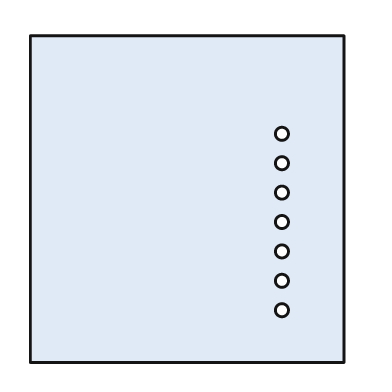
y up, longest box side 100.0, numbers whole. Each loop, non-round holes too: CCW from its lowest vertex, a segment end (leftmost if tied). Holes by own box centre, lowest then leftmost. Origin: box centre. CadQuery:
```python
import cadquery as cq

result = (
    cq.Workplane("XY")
    .moveTo(-48.0, -50.0)
    .lineTo(48.0, -50.0)
    .lineTo(48.0, 50.0)
    .lineTo(-48.0, 50.0)
    .close()
    .moveTo(29.0, -34.0)
    .circle(2.0)
    .moveTo(29.0, -25.0)
    .circle(2.0)
    .moveTo(29.0, -16.0)
    .circle(2.0)
    .moveTo(29.0, -7.0)
    .circle(2.0)
    .moveTo(29.0, 2.0)
    .circle(2.0)
    .moveTo(29.0, 11.0)
    .circle(2.0)
    .moveTo(29.0, 20.0)
    .circle(2.0)
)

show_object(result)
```